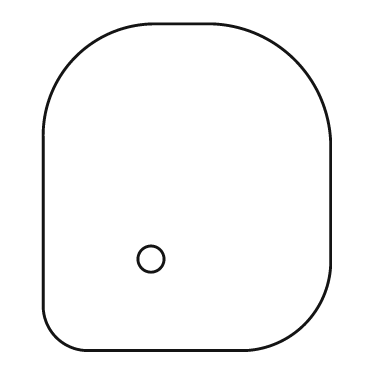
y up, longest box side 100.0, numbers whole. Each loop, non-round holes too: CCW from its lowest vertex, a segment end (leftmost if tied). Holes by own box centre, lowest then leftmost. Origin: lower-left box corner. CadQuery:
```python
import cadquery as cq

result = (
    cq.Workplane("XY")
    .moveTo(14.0, 0.0)
    .lineTo(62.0, 0.0)
    .threePointArc((80.0, 8.0), (88.0, 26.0))
    .lineTo(88.0, 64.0)
    .threePointArc((77.0, 89.0), (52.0, 100.0))
    .lineTo(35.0, 100.0)
    .threePointArc((10.0, 90.0), (0.0, 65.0))
    .lineTo(0.0, 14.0)
    .threePointArc((4.0, 4.0), (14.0, 0.0))
    .close()
    .moveTo(33.0, 28.0)
    .circle(4.0)
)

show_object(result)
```